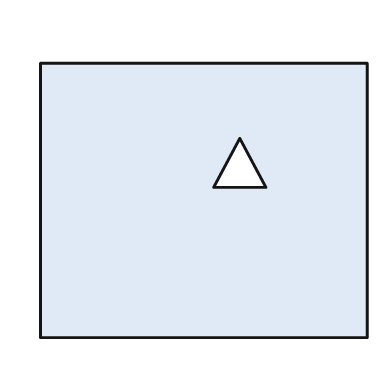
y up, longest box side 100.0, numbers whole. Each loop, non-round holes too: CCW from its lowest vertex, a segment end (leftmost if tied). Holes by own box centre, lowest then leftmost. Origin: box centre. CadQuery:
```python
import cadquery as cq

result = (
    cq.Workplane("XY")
    .moveTo(-50.0, -42.0)
    .lineTo(50.0, -42.0)
    .lineTo(50.0, 42.0)
    .lineTo(-50.0, 42.0)
    .close()
    .moveTo(3.0, 4.0)
    .lineTo(19.0, 4.0)
    .lineTo(11.0, 19.0)
    .close()
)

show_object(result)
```